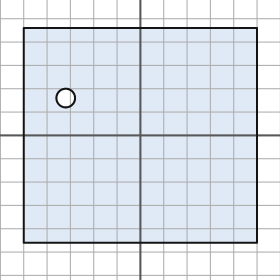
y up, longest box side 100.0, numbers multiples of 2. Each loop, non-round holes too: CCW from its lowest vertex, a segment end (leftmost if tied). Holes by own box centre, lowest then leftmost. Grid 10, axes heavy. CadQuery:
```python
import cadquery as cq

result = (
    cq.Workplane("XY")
    .moveTo(-50.0, -46.0)
    .lineTo(50.0, -46.0)
    .lineTo(50.0, 46.0)
    .lineTo(-50.0, 46.0)
    .close()
    .moveTo(-32.0, 16.0)
    .circle(4.0)
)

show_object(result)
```